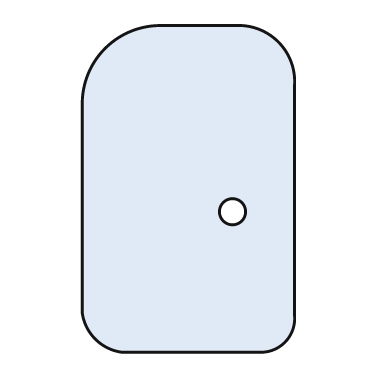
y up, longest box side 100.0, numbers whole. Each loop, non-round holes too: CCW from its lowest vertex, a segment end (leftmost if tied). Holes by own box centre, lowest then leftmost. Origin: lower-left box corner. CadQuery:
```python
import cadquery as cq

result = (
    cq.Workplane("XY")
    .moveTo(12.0, 0.0)
    .lineTo(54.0, 0.0)
    .threePointArc((62.0, 3.0), (65.0, 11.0))
    .lineTo(65.0, 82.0)
    .threePointArc((60.0, 95.0), (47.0, 100.0))
    .lineTo(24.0, 100.0)
    .threePointArc((7.0, 93.0), (0.0, 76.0))
    .lineTo(0.0, 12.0)
    .threePointArc((4.0, 4.0), (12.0, 0.0))
    .close()
    .moveTo(46.0, 43.0)
    .circle(4.0)
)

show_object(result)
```